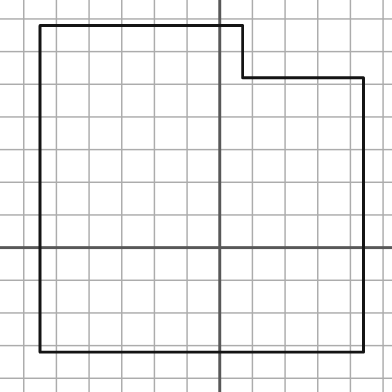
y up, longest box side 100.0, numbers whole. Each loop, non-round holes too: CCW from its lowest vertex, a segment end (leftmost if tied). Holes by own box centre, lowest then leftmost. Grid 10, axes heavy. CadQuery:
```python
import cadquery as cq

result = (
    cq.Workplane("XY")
    .moveTo(-55.0, -32.0)
    .lineTo(44.0, -32.0)
    .lineTo(44.0, 52.0)
    .lineTo(7.0, 52.0)
    .lineTo(7.0, 68.0)
    .lineTo(-55.0, 68.0)
    .close()
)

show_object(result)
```